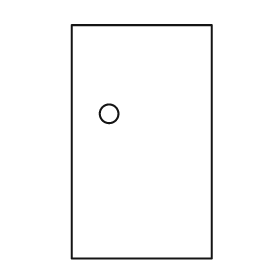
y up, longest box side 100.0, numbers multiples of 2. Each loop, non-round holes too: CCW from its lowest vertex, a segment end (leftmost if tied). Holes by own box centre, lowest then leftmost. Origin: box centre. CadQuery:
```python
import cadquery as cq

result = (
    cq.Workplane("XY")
    .moveTo(-30.0, -50.0)
    .lineTo(30.0, -50.0)
    .lineTo(30.0, 50.0)
    .lineTo(-30.0, 50.0)
    .close()
    .moveTo(-14.0, 12.0)
    .circle(4.0)
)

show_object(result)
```